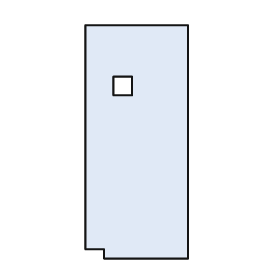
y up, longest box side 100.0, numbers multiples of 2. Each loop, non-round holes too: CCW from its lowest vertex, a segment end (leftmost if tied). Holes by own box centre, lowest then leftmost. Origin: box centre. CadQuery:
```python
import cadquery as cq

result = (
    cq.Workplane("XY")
    .moveTo(-14.0, -50.0)
    .lineTo(22.0, -50.0)
    .lineTo(22.0, 50.0)
    .lineTo(-22.0, 50.0)
    .lineTo(-22.0, -46.0)
    .lineTo(-14.0, -46.0)
    .close()
    .moveTo(-10.0, 20.0)
    .lineTo(-2.0, 20.0)
    .lineTo(-2.0, 28.0)
    .lineTo(-10.0, 28.0)
    .close()
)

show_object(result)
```